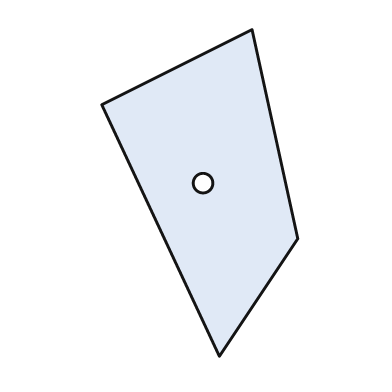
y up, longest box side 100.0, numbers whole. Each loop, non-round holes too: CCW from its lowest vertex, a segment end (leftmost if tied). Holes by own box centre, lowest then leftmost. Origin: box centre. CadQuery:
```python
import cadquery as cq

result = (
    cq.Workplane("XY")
    .moveTo(6.0, -50.0)
    .lineTo(30.0, -14.0)
    .lineTo(16.0, 50.0)
    .lineTo(-30.0, 27.0)
    .close()
    .moveTo(1.0, 3.0)
    .circle(3.0)
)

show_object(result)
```